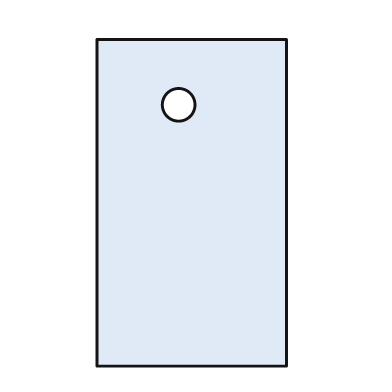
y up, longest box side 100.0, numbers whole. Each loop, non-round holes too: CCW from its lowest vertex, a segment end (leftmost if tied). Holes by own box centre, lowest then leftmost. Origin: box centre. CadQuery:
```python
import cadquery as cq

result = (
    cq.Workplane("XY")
    .moveTo(-29.0, -50.0)
    .lineTo(29.0, -50.0)
    .lineTo(29.0, 50.0)
    .lineTo(-29.0, 50.0)
    .close()
    .moveTo(-4.0, 30.0)
    .circle(5.0)
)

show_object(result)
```